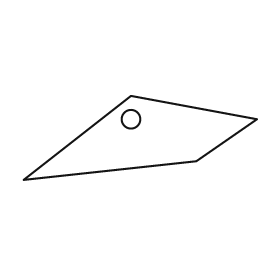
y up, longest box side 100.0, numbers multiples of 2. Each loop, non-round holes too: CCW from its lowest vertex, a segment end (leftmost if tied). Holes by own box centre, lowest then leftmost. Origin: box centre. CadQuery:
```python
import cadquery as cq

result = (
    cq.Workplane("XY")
    .moveTo(-50.0, -18.0)
    .lineTo(24.0, -10.0)
    .lineTo(50.0, 8.0)
    .lineTo(-4.0, 18.0)
    .close()
    .moveTo(-4.0, 8.0)
    .circle(4.0)
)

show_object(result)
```